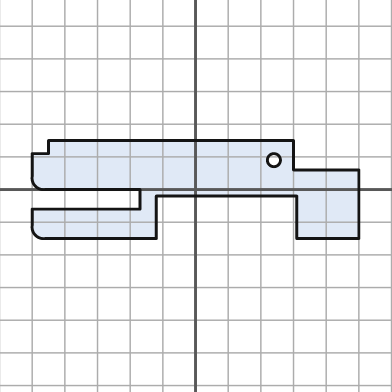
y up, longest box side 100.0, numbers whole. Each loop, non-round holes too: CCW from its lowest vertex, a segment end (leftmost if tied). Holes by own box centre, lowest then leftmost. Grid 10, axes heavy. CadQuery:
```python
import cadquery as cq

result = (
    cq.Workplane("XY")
    .moveTo(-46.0, -15.0)
    .lineTo(-12.0, -15.0)
    .lineTo(-12.0, -2.0)
    .lineTo(31.0, -2.0)
    .lineTo(31.0, -15.0)
    .lineTo(50.0, -15.0)
    .lineTo(50.0, 6.0)
    .lineTo(30.0, 6.0)
    .lineTo(30.0, 15.0)
    .lineTo(-45.0, 15.0)
    .lineTo(-45.0, 11.0)
    .lineTo(-50.0, 11.0)
    .lineTo(-50.0, 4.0)
    .threePointArc((-49.0, 1.0), (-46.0, 0.0))
    .lineTo(-17.0, 0.0)
    .lineTo(-17.0, -6.0)
    .lineTo(-50.0, -6.0)
    .lineTo(-50.0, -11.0)
    .threePointArc((-49.0, -14.0), (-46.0, -15.0))
    .close()
    .moveTo(24.0, 9.0)
    .circle(2.0)
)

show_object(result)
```